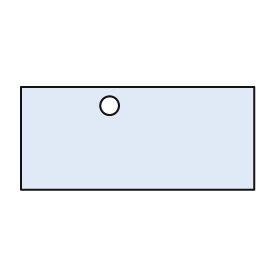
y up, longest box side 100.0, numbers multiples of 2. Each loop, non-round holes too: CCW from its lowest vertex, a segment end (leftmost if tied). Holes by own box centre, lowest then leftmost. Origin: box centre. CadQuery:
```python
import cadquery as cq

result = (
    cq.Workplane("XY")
    .moveTo(-50.0, -22.0)
    .lineTo(50.0, -22.0)
    .lineTo(50.0, 22.0)
    .lineTo(-50.0, 22.0)
    .close()
    .moveTo(-12.0, 14.0)
    .circle(4.0)
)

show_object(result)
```